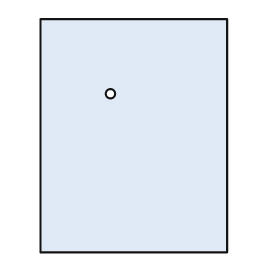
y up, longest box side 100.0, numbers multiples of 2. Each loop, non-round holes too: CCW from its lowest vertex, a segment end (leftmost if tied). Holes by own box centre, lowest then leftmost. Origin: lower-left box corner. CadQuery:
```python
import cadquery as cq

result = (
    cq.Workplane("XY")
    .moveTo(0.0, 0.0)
    .lineTo(80.0, 0.0)
    .lineTo(80.0, 100.0)
    .lineTo(0.0, 100.0)
    .close()
    .moveTo(30.0, 68.0)
    .circle(2.0)
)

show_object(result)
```